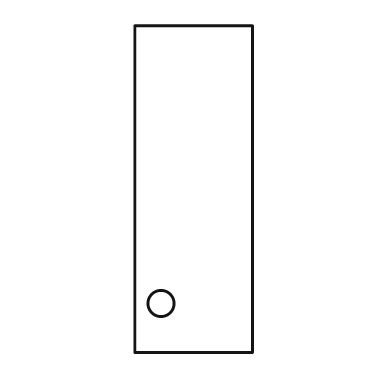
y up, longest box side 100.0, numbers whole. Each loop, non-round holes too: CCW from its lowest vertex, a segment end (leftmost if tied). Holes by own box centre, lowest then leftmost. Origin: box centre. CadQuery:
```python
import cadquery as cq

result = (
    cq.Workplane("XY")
    .moveTo(-18.0, -50.0)
    .lineTo(18.0, -50.0)
    .lineTo(18.0, 50.0)
    .lineTo(-18.0, 50.0)
    .close()
    .moveTo(-10.0, -35.0)
    .circle(4.0)
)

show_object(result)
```